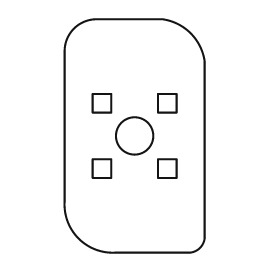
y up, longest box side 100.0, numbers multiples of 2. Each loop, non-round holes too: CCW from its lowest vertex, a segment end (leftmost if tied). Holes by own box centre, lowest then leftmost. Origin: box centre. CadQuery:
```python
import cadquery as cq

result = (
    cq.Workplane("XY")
    .moveTo(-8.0, -50.0)
    .lineTo(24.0, -50.0)
    .threePointArc((28.0, -48.0), (30.0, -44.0))
    .lineTo(30.0, 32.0)
    .threePointArc((24.0, 44.0), (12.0, 50.0))
    .lineTo(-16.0, 50.0)
    .threePointArc((-26.0, 46.0), (-30.0, 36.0))
    .lineTo(-30.0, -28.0)
    .threePointArc((-24.0, -44.0), (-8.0, -50.0))
    .close()
    .moveTo(-18.0, -18.0)
    .lineTo(-10.0, -18.0)
    .lineTo(-10.0, -10.0)
    .lineTo(-18.0, -10.0)
    .close()
    .moveTo(10.0, -18.0)
    .lineTo(18.0, -18.0)
    .lineTo(18.0, -10.0)
    .lineTo(10.0, -10.0)
    .close()
    .moveTo(0.0, 0.0)
    .circle(8.0)
    .moveTo(-18.0, 10.0)
    .lineTo(-10.0, 10.0)
    .lineTo(-10.0, 18.0)
    .lineTo(-18.0, 18.0)
    .close()
    .moveTo(10.0, 10.0)
    .lineTo(18.0, 10.0)
    .lineTo(18.0, 18.0)
    .lineTo(10.0, 18.0)
    .close()
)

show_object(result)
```